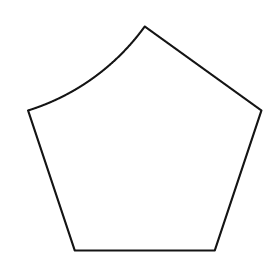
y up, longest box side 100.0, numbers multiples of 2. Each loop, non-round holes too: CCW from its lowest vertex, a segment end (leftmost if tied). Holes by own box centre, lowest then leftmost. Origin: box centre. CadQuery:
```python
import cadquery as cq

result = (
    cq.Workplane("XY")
    .moveTo(-30.0, -48.0)
    .lineTo(30.0, -48.0)
    .lineTo(50.0, 12.0)
    .lineTo(0.0, 48.0)
    .threePointArc((-22.0, 26.0), (-50.0, 12.0))
    .close()
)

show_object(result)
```